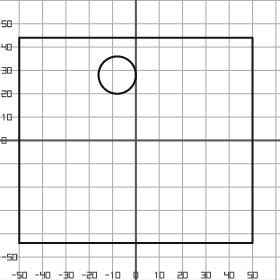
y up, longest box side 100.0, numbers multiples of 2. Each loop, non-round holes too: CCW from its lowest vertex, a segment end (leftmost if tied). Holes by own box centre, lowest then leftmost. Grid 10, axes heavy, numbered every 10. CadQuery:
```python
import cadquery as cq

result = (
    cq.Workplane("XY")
    .moveTo(-50.0, -44.0)
    .lineTo(50.0, -44.0)
    .lineTo(50.0, 44.0)
    .lineTo(-50.0, 44.0)
    .close()
    .moveTo(-8.0, 28.0)
    .circle(8.0)
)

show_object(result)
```